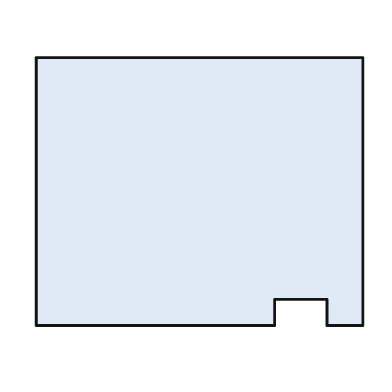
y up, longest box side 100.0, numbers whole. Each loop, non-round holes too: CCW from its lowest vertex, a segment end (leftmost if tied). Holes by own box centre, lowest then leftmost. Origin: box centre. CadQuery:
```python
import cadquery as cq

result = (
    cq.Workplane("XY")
    .moveTo(-50.0, -41.0)
    .lineTo(23.0, -41.0)
    .lineTo(23.0, -33.0)
    .lineTo(39.0, -33.0)
    .lineTo(39.0, -41.0)
    .lineTo(50.0, -41.0)
    .lineTo(50.0, 41.0)
    .lineTo(-50.0, 41.0)
    .close()
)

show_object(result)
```